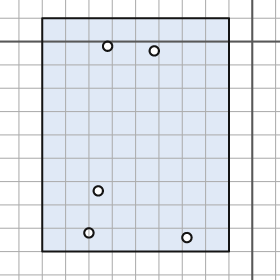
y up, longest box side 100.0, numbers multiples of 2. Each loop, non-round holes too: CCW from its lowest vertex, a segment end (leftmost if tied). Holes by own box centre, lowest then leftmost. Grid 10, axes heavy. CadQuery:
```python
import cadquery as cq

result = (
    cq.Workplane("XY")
    .moveTo(-90.0, -90.0)
    .lineTo(-10.0, -90.0)
    .lineTo(-10.0, 10.0)
    .lineTo(-90.0, 10.0)
    .close()
    .moveTo(-28.0, -84.0)
    .circle(2.0)
    .moveTo(-70.0, -82.0)
    .circle(2.0)
    .moveTo(-66.0, -64.0)
    .circle(2.0)
    .moveTo(-42.0, -4.0)
    .circle(2.0)
    .moveTo(-62.0, -2.0)
    .circle(2.0)
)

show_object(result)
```